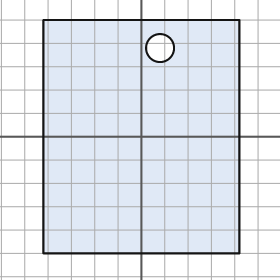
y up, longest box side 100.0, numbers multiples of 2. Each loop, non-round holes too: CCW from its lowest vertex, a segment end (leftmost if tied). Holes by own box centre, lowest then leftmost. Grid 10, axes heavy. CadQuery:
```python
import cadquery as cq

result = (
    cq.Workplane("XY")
    .moveTo(-42.0, -50.0)
    .lineTo(42.0, -50.0)
    .lineTo(42.0, 50.0)
    .lineTo(-42.0, 50.0)
    .close()
    .moveTo(8.0, 38.0)
    .circle(6.0)
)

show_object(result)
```